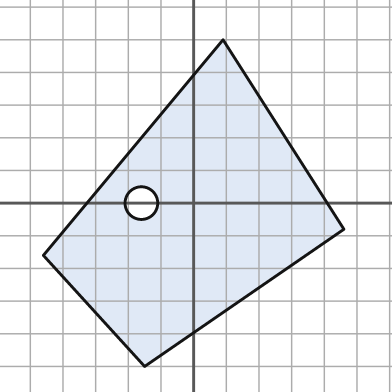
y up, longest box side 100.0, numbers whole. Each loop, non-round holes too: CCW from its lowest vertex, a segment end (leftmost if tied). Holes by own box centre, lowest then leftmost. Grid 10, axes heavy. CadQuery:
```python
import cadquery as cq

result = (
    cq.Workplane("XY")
    .moveTo(-15.0, -50.0)
    .lineTo(46.0, -8.0)
    .lineTo(9.0, 50.0)
    .lineTo(-46.0, -16.0)
    .close()
    .moveTo(-16.0, 0.0)
    .circle(5.0)
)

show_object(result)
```